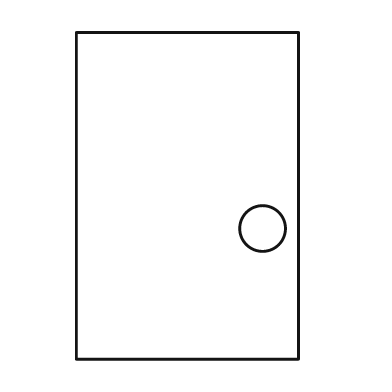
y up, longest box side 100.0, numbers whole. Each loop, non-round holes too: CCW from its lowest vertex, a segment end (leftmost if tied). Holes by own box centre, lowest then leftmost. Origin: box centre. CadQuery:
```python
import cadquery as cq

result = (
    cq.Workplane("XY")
    .moveTo(-34.0, -50.0)
    .lineTo(34.0, -50.0)
    .lineTo(34.0, 50.0)
    .lineTo(-34.0, 50.0)
    .close()
    .moveTo(23.0, -10.0)
    .circle(7.0)
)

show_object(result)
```